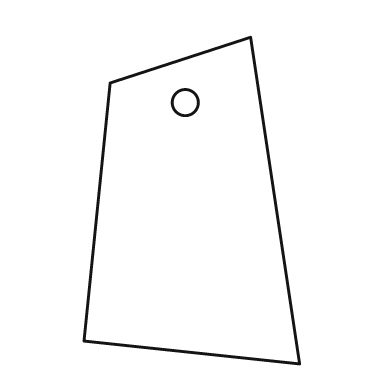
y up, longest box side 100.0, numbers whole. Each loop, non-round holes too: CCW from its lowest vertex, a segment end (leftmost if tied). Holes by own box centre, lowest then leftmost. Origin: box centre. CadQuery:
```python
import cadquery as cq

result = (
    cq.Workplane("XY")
    .moveTo(33.0, -50.0)
    .lineTo(18.0, 50.0)
    .lineTo(-25.0, 36.0)
    .lineTo(-33.0, -43.0)
    .close()
    .moveTo(-2.0, 30.0)
    .circle(4.0)
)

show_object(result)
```